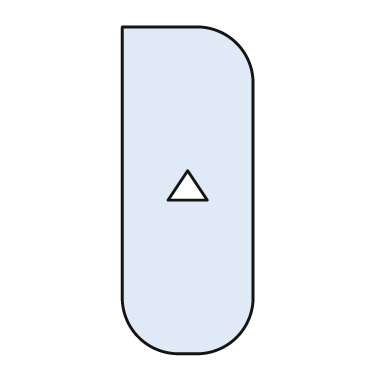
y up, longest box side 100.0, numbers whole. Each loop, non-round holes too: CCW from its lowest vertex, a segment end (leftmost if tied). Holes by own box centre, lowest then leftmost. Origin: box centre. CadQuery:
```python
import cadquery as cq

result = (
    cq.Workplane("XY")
    .moveTo(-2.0, -50.0)
    .lineTo(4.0, -50.0)
    .threePointArc((15.0, -45.0), (20.0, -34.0))
    .lineTo(20.0, 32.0)
    .threePointArc((15.0, 45.0), (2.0, 50.0))
    .lineTo(-20.0, 50.0)
    .lineTo(-20.0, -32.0)
    .threePointArc((-15.0, -45.0), (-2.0, -50.0))
    .close()
    .moveTo(-6.0, -3.0)
    .lineTo(6.0, -3.0)
    .lineTo(0.0, 6.0)
    .close()
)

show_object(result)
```